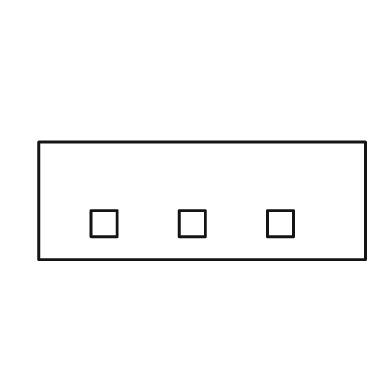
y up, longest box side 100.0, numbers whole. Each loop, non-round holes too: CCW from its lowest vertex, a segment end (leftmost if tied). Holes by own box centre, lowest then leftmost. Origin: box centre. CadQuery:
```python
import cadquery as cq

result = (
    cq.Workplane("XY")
    .moveTo(-50.0, -18.0)
    .lineTo(50.0, -18.0)
    .lineTo(50.0, 18.0)
    .lineTo(-50.0, 18.0)
    .close()
    .moveTo(-34.0, -11.0)
    .lineTo(-26.0, -11.0)
    .lineTo(-26.0, -3.0)
    .lineTo(-34.0, -3.0)
    .close()
    .moveTo(-7.0, -11.0)
    .lineTo(1.0, -11.0)
    .lineTo(1.0, -3.0)
    .lineTo(-7.0, -3.0)
    .close()
    .moveTo(20.0, -11.0)
    .lineTo(28.0, -11.0)
    .lineTo(28.0, -3.0)
    .lineTo(20.0, -3.0)
    .close()
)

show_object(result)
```